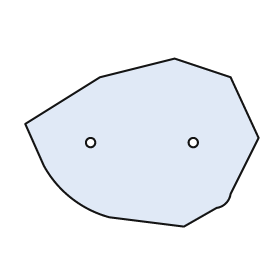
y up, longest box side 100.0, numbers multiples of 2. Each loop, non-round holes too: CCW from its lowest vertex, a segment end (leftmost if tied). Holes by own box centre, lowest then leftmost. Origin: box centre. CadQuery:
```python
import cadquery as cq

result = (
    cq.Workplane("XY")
    .moveTo(18.0, -36.0)
    .lineTo(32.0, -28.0)
    .threePointArc((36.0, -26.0), (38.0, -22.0))
    .lineTo(50.0, 2.0)
    .lineTo(38.0, 28.0)
    .lineTo(14.0, 36.0)
    .lineTo(-18.0, 28.0)
    .lineTo(-50.0, 8.0)
    .lineTo(-42.0, -10.0)
    .threePointArc((-30.0, -24.0), (-14.0, -32.0))
    .close()
    .moveTo(-22.0, 0.0)
    .circle(2.0)
    .moveTo(22.0, 0.0)
    .circle(2.0)
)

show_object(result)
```